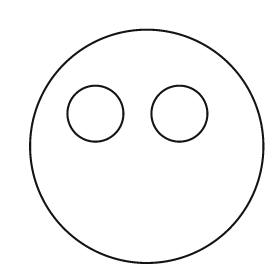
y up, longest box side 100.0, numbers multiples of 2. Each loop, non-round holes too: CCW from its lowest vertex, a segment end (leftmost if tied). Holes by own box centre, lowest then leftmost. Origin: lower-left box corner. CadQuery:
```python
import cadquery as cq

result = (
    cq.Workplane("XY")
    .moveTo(50.0, 50.0)
    .circle(50.0)
    .moveTo(28.0, 64.0)
    .circle(12.0)
    .moveTo(64.0, 64.0)
    .circle(12.0)
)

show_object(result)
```